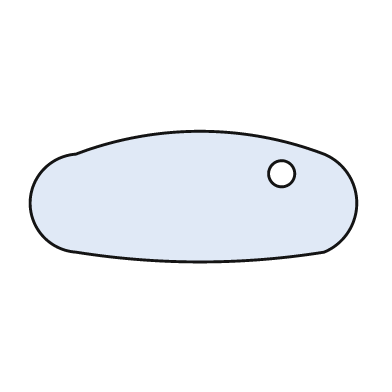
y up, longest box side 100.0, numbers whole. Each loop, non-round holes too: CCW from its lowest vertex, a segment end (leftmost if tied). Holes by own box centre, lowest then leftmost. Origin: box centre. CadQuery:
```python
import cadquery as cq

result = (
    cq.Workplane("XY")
    .moveTo(-36.0, -17.0)
    .threePointArc((2.0, -20.0), (40.0, -17.0))
    .threePointArc((50.0, -2.0), (40.0, 13.0))
    .threePointArc((2.0, 20.0), (-36.0, 13.0))
    .threePointArc((-50.0, -2.0), (-36.0, -17.0))
    .close()
    .moveTo(27.0, 7.0)
    .circle(4.0)
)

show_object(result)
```